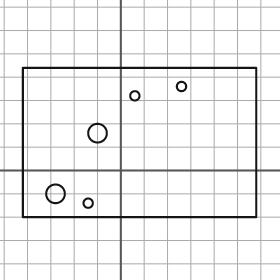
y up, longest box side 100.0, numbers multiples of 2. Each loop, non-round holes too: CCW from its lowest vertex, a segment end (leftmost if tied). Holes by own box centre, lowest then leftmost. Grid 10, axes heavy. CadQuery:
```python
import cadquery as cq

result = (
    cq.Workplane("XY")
    .moveTo(-42.0, -20.0)
    .lineTo(58.0, -20.0)
    .lineTo(58.0, 44.0)
    .lineTo(-42.0, 44.0)
    .close()
    .moveTo(-14.0, -14.0)
    .circle(2.0)
    .moveTo(-28.0, -10.0)
    .circle(4.0)
    .moveTo(-10.0, 16.0)
    .circle(4.0)
    .moveTo(6.0, 32.0)
    .circle(2.0)
    .moveTo(26.0, 36.0)
    .circle(2.0)
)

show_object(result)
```